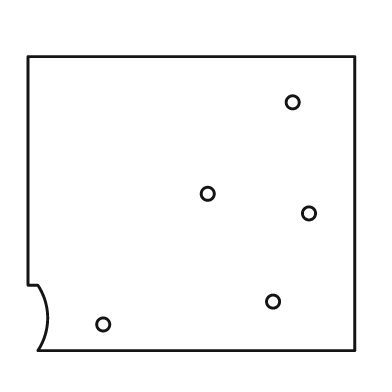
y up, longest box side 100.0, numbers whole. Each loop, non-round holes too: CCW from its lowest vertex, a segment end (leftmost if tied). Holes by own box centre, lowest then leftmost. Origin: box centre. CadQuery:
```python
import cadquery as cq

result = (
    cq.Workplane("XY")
    .moveTo(-47.0, -45.0)
    .lineTo(50.0, -45.0)
    .lineTo(50.0, 45.0)
    .lineTo(-50.0, 45.0)
    .lineTo(-50.0, -25.0)
    .lineTo(-47.0, -25.0)
    .threePointArc((-44.0, -35.0), (-47.0, -45.0))
    .close()
    .moveTo(-27.0, -37.0)
    .circle(2.0)
    .moveTo(25.0, -30.0)
    .circle(2.0)
    .moveTo(36.0, -3.0)
    .circle(2.0)
    .moveTo(5.0, 3.0)
    .circle(2.0)
    .moveTo(31.0, 31.0)
    .circle(2.0)
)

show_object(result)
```